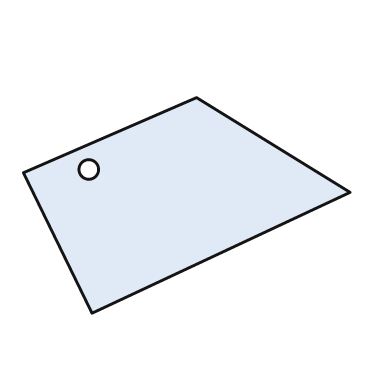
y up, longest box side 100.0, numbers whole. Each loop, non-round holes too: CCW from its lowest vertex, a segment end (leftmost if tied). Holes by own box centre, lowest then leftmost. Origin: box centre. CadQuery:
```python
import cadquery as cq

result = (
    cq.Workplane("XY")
    .moveTo(-29.0, -33.0)
    .lineTo(50.0, 4.0)
    .lineTo(3.0, 33.0)
    .lineTo(-50.0, 10.0)
    .close()
    .moveTo(-30.0, 11.0)
    .circle(3.0)
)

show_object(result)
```